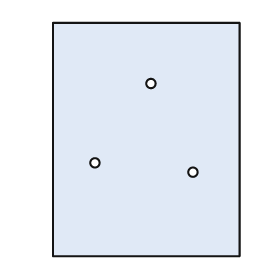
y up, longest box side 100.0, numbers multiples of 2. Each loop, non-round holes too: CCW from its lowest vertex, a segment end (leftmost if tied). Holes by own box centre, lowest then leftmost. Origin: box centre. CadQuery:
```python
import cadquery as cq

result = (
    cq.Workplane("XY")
    .moveTo(-40.0, -50.0)
    .lineTo(40.0, -50.0)
    .lineTo(40.0, 50.0)
    .lineTo(-40.0, 50.0)
    .close()
    .moveTo(20.0, -14.0)
    .circle(2.0)
    .moveTo(-22.0, -10.0)
    .circle(2.0)
    .moveTo(2.0, 24.0)
    .circle(2.0)
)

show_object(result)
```